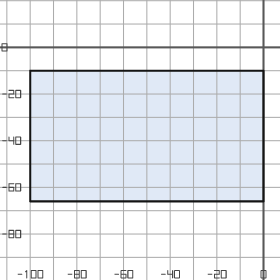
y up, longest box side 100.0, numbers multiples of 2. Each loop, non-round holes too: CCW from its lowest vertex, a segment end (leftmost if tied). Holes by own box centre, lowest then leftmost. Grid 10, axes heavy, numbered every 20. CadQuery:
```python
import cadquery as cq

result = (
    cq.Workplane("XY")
    .moveTo(-100.0, -66.0)
    .lineTo(0.0, -66.0)
    .lineTo(0.0, -10.0)
    .lineTo(-100.0, -10.0)
    .close()
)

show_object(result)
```